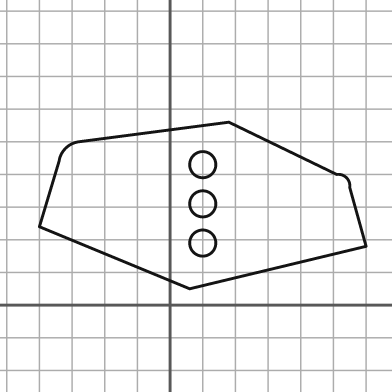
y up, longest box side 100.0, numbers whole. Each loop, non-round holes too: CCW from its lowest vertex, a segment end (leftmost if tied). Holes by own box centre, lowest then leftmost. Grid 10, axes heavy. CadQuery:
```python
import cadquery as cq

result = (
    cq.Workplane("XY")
    .moveTo(6.0, 5.0)
    .lineTo(60.0, 18.0)
    .lineTo(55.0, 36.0)
    .threePointArc((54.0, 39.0), (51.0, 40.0))
    .lineTo(18.0, 56.0)
    .lineTo(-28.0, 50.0)
    .threePointArc((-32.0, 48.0), (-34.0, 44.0))
    .lineTo(-40.0, 24.0)
    .close()
    .moveTo(10.0, 19.0)
    .circle(4.0)
    .moveTo(10.0, 31.0)
    .circle(4.0)
    .moveTo(10.0, 43.0)
    .circle(4.0)
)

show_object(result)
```